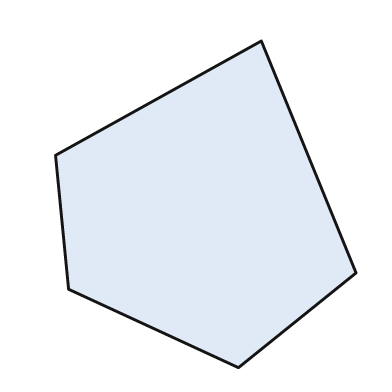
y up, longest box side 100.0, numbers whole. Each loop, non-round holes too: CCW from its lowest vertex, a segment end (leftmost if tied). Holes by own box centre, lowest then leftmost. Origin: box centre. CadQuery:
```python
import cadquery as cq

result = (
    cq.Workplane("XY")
    .moveTo(10.0, -50.0)
    .lineTo(46.0, -21.0)
    .lineTo(17.0, 50.0)
    .lineTo(-46.0, 15.0)
    .lineTo(-42.0, -26.0)
    .close()
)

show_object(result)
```